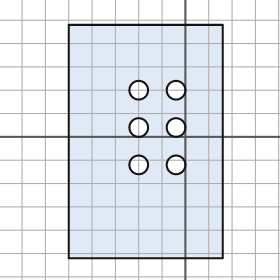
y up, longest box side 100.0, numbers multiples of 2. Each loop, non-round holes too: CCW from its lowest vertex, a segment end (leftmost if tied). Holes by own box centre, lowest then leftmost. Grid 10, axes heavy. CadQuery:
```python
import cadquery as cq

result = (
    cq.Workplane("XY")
    .moveTo(-50.0, -52.0)
    .lineTo(16.0, -52.0)
    .lineTo(16.0, 48.0)
    .lineTo(-50.0, 48.0)
    .close()
    .moveTo(-20.0, -12.0)
    .circle(4.0)
    .moveTo(-4.0, -12.0)
    .circle(4.0)
    .moveTo(-20.0, 4.0)
    .circle(4.0)
    .moveTo(-4.0, 4.0)
    .circle(4.0)
    .moveTo(-20.0, 20.0)
    .circle(4.0)
    .moveTo(-4.0, 20.0)
    .circle(4.0)
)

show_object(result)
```